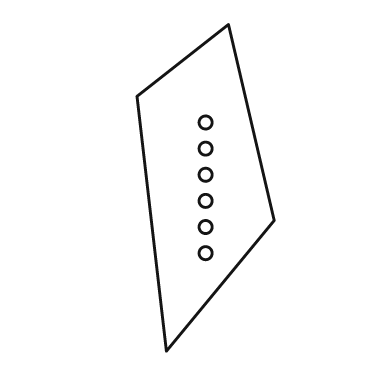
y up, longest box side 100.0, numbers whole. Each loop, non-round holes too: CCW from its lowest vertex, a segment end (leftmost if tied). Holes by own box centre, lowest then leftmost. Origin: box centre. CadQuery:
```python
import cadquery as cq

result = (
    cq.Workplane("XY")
    .moveTo(-12.0, -50.0)
    .lineTo(21.0, -10.0)
    .lineTo(7.0, 50.0)
    .lineTo(-21.0, 28.0)
    .close()
    .moveTo(0.0, -20.0)
    .circle(2.0)
    .moveTo(0.0, -12.0)
    .circle(2.0)
    .moveTo(0.0, -4.0)
    .circle(2.0)
    .moveTo(0.0, 4.0)
    .circle(2.0)
    .moveTo(0.0, 12.0)
    .circle(2.0)
    .moveTo(0.0, 20.0)
    .circle(2.0)
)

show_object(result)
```